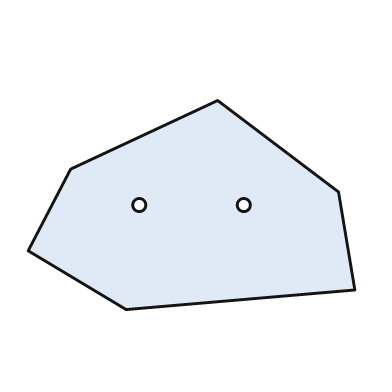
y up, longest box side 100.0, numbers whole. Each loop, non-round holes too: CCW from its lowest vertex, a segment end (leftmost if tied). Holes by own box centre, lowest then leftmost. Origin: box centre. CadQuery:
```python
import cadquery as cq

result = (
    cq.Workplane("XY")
    .moveTo(-20.0, -32.0)
    .lineTo(50.0, -26.0)
    .lineTo(45.0, 4.0)
    .lineTo(8.0, 32.0)
    .lineTo(-37.0, 11.0)
    .lineTo(-50.0, -14.0)
    .close()
    .moveTo(-16.0, 0.0)
    .circle(2.0)
    .moveTo(16.0, 0.0)
    .circle(2.0)
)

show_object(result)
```